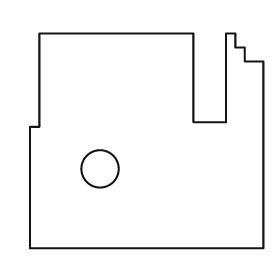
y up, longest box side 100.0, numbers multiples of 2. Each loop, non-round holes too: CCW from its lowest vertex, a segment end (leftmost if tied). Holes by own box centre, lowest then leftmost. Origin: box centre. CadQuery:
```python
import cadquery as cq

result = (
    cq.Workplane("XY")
    .moveTo(-50.0, -46.0)
    .lineTo(50.0, -46.0)
    .lineTo(50.0, 34.0)
    .lineTo(42.0, 34.0)
    .lineTo(42.0, 40.0)
    .lineTo(38.0, 40.0)
    .lineTo(38.0, 46.0)
    .lineTo(34.0, 46.0)
    .lineTo(34.0, 8.0)
    .lineTo(20.0, 8.0)
    .lineTo(20.0, 46.0)
    .lineTo(-46.0, 46.0)
    .lineTo(-46.0, 6.0)
    .lineTo(-50.0, 6.0)
    .close()
    .moveTo(-20.0, -12.0)
    .circle(8.0)
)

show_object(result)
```